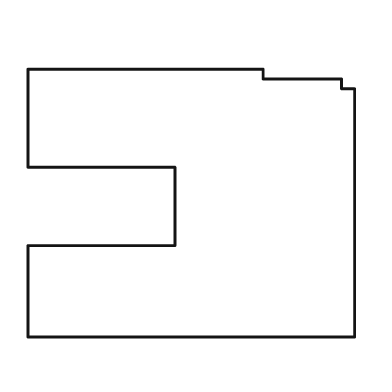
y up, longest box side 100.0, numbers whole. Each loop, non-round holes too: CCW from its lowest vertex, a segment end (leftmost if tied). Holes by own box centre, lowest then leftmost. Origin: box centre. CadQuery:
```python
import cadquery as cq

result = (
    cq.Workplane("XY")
    .moveTo(-50.0, -41.0)
    .lineTo(50.0, -41.0)
    .lineTo(50.0, 35.0)
    .lineTo(46.0, 35.0)
    .lineTo(46.0, 38.0)
    .lineTo(22.0, 38.0)
    .lineTo(22.0, 41.0)
    .lineTo(-50.0, 41.0)
    .lineTo(-50.0, 11.0)
    .lineTo(-5.0, 11.0)
    .lineTo(-5.0, -13.0)
    .lineTo(-50.0, -13.0)
    .close()
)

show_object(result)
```